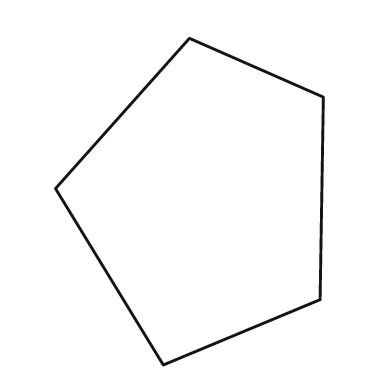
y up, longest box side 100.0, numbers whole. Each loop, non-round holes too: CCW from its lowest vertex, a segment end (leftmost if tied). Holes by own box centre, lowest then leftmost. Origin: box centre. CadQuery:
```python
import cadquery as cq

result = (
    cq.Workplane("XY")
    .moveTo(-8.0, -50.0)
    .lineTo(40.0, -30.0)
    .lineTo(41.0, 32.0)
    .lineTo(0.0, 50.0)
    .lineTo(-41.0, 4.0)
    .close()
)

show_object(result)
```